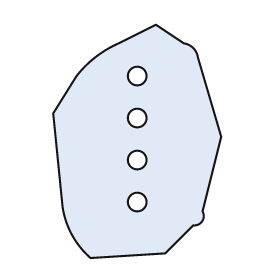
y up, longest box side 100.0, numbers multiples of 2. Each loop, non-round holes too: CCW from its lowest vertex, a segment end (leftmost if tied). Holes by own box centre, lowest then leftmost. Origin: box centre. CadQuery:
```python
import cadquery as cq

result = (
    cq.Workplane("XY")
    .moveTo(-20.0, -50.0)
    .lineTo(12.0, -48.0)
    .lineTo(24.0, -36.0)
    .threePointArc((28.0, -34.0), (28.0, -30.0))
    .lineTo(36.0, 2.0)
    .lineTo(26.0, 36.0)
    .threePointArc((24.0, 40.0), (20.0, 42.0))
    .lineTo(8.0, 50.0)
    .lineTo(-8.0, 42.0)
    .threePointArc((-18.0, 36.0), (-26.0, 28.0))
    .lineTo(-36.0, 12.0)
    .lineTo(-32.0, -28.0)
    .threePointArc((-28.0, -40.0), (-20.0, -50.0))
    .close()
    .moveTo(0.0, -26.0)
    .circle(4.0)
    .moveTo(0.0, -8.0)
    .circle(4.0)
    .moveTo(0.0, 10.0)
    .circle(4.0)
    .moveTo(0.0, 28.0)
    .circle(4.0)
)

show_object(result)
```